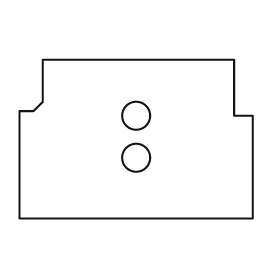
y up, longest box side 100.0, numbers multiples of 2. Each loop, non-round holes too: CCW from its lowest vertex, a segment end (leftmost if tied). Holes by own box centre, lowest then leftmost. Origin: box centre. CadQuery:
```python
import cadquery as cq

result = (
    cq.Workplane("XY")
    .moveTo(-50.0, -34.0)
    .lineTo(50.0, -34.0)
    .lineTo(50.0, 10.0)
    .lineTo(42.0, 10.0)
    .lineTo(42.0, 34.0)
    .lineTo(-40.0, 34.0)
    .lineTo(-40.0, 16.0)
    .lineTo(-44.0, 12.0)
    .lineTo(-50.0, 12.0)
    .close()
    .moveTo(0.0, -8.0)
    .circle(6.0)
    .moveTo(0.0, 10.0)
    .circle(6.0)
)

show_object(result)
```